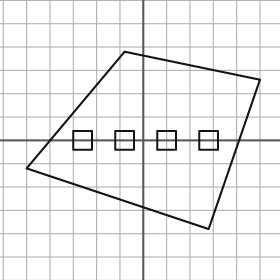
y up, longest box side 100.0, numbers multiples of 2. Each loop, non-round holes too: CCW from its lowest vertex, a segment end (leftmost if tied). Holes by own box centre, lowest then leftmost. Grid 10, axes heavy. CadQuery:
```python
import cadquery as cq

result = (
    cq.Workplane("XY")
    .moveTo(28.0, -38.0)
    .lineTo(50.0, 26.0)
    .lineTo(-8.0, 38.0)
    .lineTo(-50.0, -12.0)
    .close()
    .moveTo(-30.0, -4.0)
    .lineTo(-22.0, -4.0)
    .lineTo(-22.0, 4.0)
    .lineTo(-30.0, 4.0)
    .close()
    .moveTo(-12.0, -4.0)
    .lineTo(-4.0, -4.0)
    .lineTo(-4.0, 4.0)
    .lineTo(-12.0, 4.0)
    .close()
    .moveTo(6.0, -4.0)
    .lineTo(14.0, -4.0)
    .lineTo(14.0, 4.0)
    .lineTo(6.0, 4.0)
    .close()
    .moveTo(24.0, -4.0)
    .lineTo(32.0, -4.0)
    .lineTo(32.0, 4.0)
    .lineTo(24.0, 4.0)
    .close()
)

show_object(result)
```